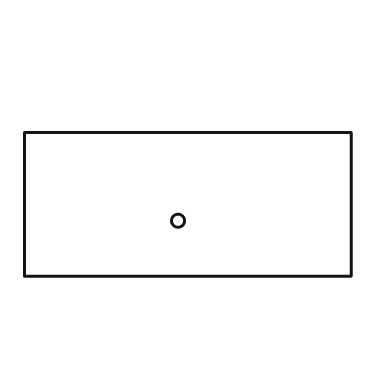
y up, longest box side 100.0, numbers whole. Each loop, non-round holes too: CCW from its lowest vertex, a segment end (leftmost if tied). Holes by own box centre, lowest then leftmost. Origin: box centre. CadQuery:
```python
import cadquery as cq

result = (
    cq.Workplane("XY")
    .moveTo(-50.0, -22.0)
    .lineTo(50.0, -22.0)
    .lineTo(50.0, 22.0)
    .lineTo(-50.0, 22.0)
    .close()
    .moveTo(-3.0, -5.0)
    .circle(2.0)
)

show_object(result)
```